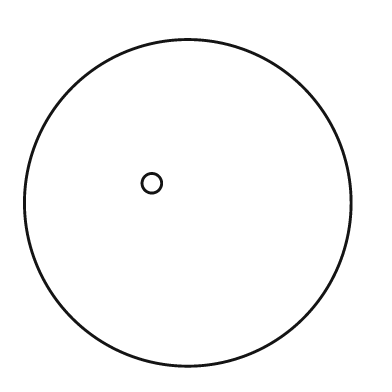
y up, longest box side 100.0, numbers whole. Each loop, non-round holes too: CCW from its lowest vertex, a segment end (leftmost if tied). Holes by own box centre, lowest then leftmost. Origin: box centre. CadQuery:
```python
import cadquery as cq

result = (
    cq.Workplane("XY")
    .moveTo(0.0, 0.0)
    .circle(50.0)
    .moveTo(-11.0, 6.0)
    .circle(3.0)
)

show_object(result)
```